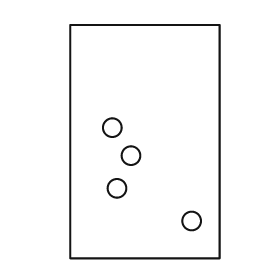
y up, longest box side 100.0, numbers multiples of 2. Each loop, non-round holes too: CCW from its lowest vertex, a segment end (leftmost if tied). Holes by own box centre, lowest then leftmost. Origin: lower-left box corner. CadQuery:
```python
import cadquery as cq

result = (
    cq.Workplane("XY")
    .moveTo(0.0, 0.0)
    .lineTo(64.0, 0.0)
    .lineTo(64.0, 100.0)
    .lineTo(0.0, 100.0)
    .close()
    .moveTo(52.0, 16.0)
    .circle(4.0)
    .moveTo(20.0, 30.0)
    .circle(4.0)
    .moveTo(26.0, 44.0)
    .circle(4.0)
    .moveTo(18.0, 56.0)
    .circle(4.0)
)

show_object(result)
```